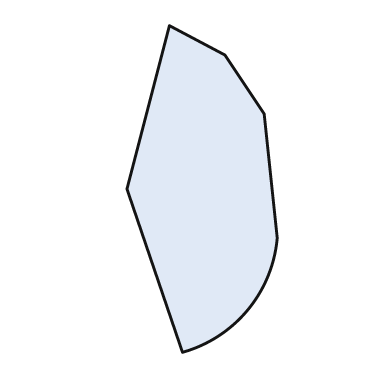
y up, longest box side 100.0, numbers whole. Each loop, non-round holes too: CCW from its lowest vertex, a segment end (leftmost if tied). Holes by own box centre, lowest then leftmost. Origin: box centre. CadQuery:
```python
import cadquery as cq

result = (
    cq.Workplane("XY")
    .moveTo(-6.0, -50.0)
    .threePointArc((14.0, -37.0), (23.0, -15.0))
    .lineTo(19.0, 23.0)
    .lineTo(7.0, 41.0)
    .lineTo(-10.0, 50.0)
    .lineTo(-23.0, 0.0)
    .close()
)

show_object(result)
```